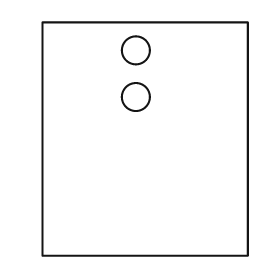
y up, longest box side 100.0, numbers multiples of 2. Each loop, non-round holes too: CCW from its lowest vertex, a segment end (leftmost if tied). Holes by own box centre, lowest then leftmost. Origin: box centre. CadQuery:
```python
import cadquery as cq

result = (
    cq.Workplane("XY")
    .moveTo(-44.0, -50.0)
    .lineTo(44.0, -50.0)
    .lineTo(44.0, 50.0)
    .lineTo(-44.0, 50.0)
    .close()
    .moveTo(-4.0, 18.0)
    .circle(6.0)
    .moveTo(-4.0, 38.0)
    .circle(6.0)
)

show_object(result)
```